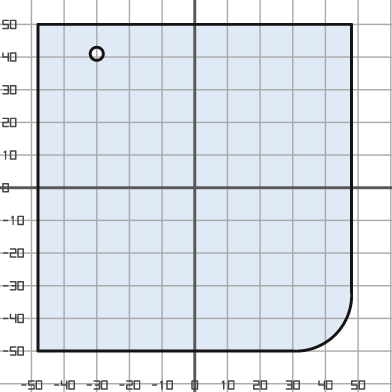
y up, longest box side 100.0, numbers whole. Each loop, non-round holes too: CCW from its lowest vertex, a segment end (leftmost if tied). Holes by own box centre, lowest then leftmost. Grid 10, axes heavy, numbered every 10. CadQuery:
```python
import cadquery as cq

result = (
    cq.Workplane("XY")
    .moveTo(-48.0, -50.0)
    .lineTo(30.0, -50.0)
    .threePointArc((43.0, -45.0), (48.0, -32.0))
    .lineTo(48.0, 50.0)
    .lineTo(-48.0, 50.0)
    .close()
    .moveTo(-30.0, 41.0)
    .circle(2.0)
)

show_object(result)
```